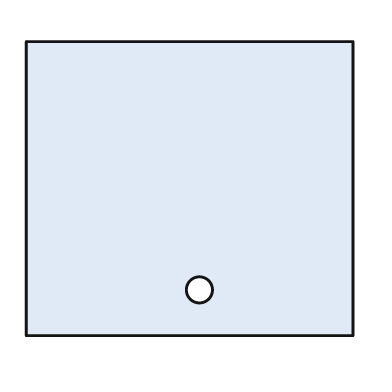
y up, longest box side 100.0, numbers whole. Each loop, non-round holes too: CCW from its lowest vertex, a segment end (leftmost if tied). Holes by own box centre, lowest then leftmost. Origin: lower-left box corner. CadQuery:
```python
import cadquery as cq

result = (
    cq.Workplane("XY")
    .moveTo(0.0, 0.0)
    .lineTo(100.0, 0.0)
    .lineTo(100.0, 90.0)
    .lineTo(0.0, 90.0)
    .close()
    .moveTo(53.0, 14.0)
    .circle(4.0)
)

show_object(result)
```